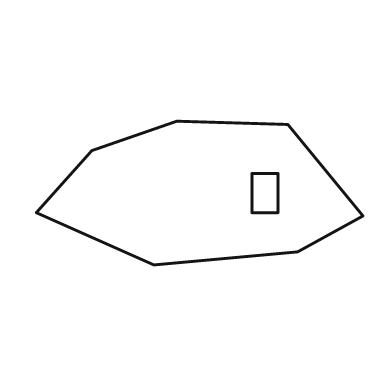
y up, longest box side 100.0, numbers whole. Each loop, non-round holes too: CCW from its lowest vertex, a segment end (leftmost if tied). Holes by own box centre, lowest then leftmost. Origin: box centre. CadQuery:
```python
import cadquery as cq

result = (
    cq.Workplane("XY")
    .moveTo(-14.0, -22.0)
    .lineTo(30.0, -18.0)
    .lineTo(50.0, -7.0)
    .lineTo(27.0, 21.0)
    .lineTo(-7.0, 22.0)
    .lineTo(-33.0, 13.0)
    .lineTo(-50.0, -6.0)
    .close()
    .moveTo(16.0, -6.0)
    .lineTo(24.0, -6.0)
    .lineTo(24.0, 6.0)
    .lineTo(16.0, 6.0)
    .close()
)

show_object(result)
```